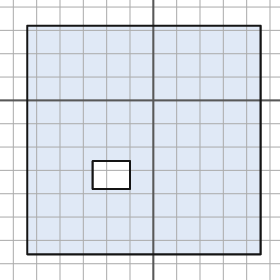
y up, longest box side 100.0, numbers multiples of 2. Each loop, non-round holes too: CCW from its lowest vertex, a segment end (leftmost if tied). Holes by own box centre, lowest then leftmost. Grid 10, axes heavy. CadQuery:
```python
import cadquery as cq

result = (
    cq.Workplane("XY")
    .moveTo(-54.0, -66.0)
    .lineTo(46.0, -66.0)
    .lineTo(46.0, 32.0)
    .lineTo(-54.0, 32.0)
    .close()
    .moveTo(-26.0, -38.0)
    .lineTo(-10.0, -38.0)
    .lineTo(-10.0, -26.0)
    .lineTo(-26.0, -26.0)
    .close()
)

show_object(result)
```